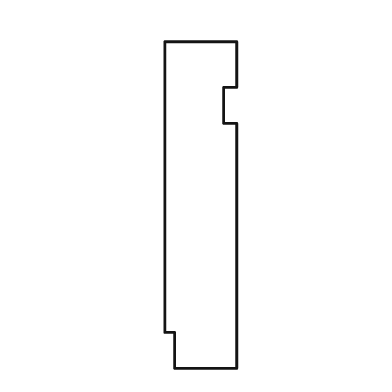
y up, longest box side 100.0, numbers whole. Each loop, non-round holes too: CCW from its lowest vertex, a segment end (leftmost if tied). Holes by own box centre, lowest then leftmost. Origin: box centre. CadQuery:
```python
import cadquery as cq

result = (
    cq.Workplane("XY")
    .moveTo(-8.0, -50.0)
    .lineTo(11.0, -50.0)
    .lineTo(11.0, 25.0)
    .lineTo(7.0, 25.0)
    .lineTo(7.0, 36.0)
    .lineTo(11.0, 36.0)
    .lineTo(11.0, 50.0)
    .lineTo(-11.0, 50.0)
    .lineTo(-11.0, -39.0)
    .lineTo(-8.0, -39.0)
    .close()
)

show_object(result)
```